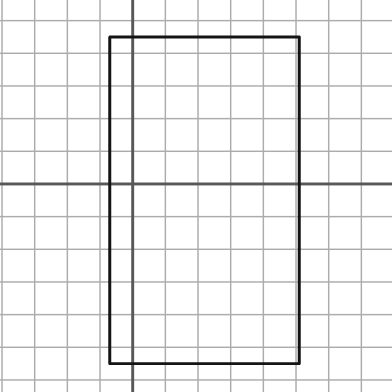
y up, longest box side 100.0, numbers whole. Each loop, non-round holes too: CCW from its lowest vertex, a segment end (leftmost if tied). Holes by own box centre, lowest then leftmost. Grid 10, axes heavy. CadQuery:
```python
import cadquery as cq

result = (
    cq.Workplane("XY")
    .moveTo(-7.0, -55.0)
    .lineTo(51.0, -55.0)
    .lineTo(51.0, 45.0)
    .lineTo(-7.0, 45.0)
    .close()
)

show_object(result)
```